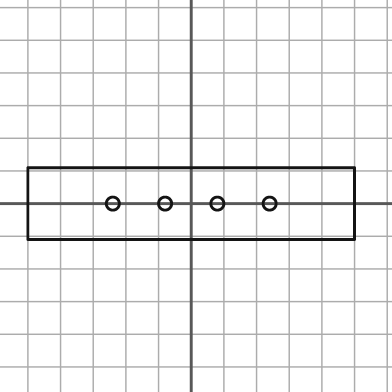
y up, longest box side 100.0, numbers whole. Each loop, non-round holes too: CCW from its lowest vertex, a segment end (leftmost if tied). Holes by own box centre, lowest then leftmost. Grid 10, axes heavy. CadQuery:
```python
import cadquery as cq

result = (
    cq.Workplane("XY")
    .moveTo(-50.0, -11.0)
    .lineTo(50.0, -11.0)
    .lineTo(50.0, 11.0)
    .lineTo(-50.0, 11.0)
    .close()
    .moveTo(-24.0, 0.0)
    .circle(2.0)
    .moveTo(-8.0, 0.0)
    .circle(2.0)
    .moveTo(8.0, 0.0)
    .circle(2.0)
    .moveTo(24.0, 0.0)
    .circle(2.0)
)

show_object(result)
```